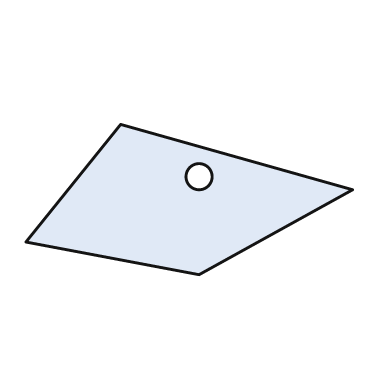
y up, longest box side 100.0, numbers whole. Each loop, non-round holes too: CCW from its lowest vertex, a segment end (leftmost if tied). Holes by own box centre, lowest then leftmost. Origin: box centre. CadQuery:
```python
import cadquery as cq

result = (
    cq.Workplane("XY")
    .moveTo(3.0, -23.0)
    .lineTo(50.0, 3.0)
    .lineTo(-21.0, 23.0)
    .lineTo(-50.0, -13.0)
    .close()
    .moveTo(3.0, 7.0)
    .circle(4.0)
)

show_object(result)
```